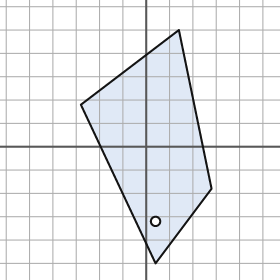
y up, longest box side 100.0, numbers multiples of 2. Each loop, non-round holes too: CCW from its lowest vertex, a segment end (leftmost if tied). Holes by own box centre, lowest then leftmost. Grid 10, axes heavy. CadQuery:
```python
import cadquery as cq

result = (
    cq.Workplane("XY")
    .moveTo(4.0, -50.0)
    .lineTo(28.0, -18.0)
    .lineTo(14.0, 50.0)
    .lineTo(-28.0, 18.0)
    .close()
    .moveTo(4.0, -32.0)
    .circle(2.0)
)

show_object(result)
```